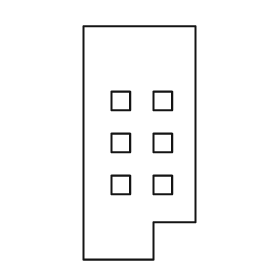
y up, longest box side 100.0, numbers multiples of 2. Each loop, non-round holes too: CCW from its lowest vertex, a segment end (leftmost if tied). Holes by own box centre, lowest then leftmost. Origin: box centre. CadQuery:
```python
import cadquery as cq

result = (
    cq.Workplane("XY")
    .moveTo(-24.0, -50.0)
    .lineTo(6.0, -50.0)
    .lineTo(6.0, -34.0)
    .lineTo(24.0, -34.0)
    .lineTo(24.0, 50.0)
    .lineTo(-24.0, 50.0)
    .close()
    .moveTo(-12.0, -22.0)
    .lineTo(-4.0, -22.0)
    .lineTo(-4.0, -14.0)
    .lineTo(-12.0, -14.0)
    .close()
    .moveTo(6.0, -22.0)
    .lineTo(14.0, -22.0)
    .lineTo(14.0, -14.0)
    .lineTo(6.0, -14.0)
    .close()
    .moveTo(-12.0, -4.0)
    .lineTo(-4.0, -4.0)
    .lineTo(-4.0, 4.0)
    .lineTo(-12.0, 4.0)
    .close()
    .moveTo(6.0, -4.0)
    .lineTo(14.0, -4.0)
    .lineTo(14.0, 4.0)
    .lineTo(6.0, 4.0)
    .close()
    .moveTo(-12.0, 14.0)
    .lineTo(-4.0, 14.0)
    .lineTo(-4.0, 22.0)
    .lineTo(-12.0, 22.0)
    .close()
    .moveTo(6.0, 14.0)
    .lineTo(14.0, 14.0)
    .lineTo(14.0, 22.0)
    .lineTo(6.0, 22.0)
    .close()
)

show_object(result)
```